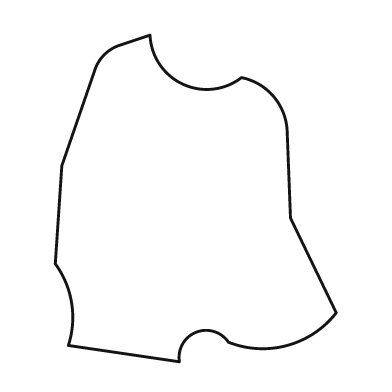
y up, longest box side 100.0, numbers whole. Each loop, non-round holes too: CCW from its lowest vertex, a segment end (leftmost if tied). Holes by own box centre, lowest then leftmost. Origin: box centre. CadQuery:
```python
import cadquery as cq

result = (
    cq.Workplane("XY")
    .moveTo(-5.0, -50.0)
    .threePointArc((0.0, -41.0), (10.0, -44.0))
    .threePointArc((28.0, -45.0), (43.0, -35.0))
    .lineTo(29.0, -6.0)
    .lineTo(28.0, 20.0)
    .threePointArc((24.0, 31.0), (14.0, 37.0))
    .threePointArc((-4.0, 35.0), (-14.0, 50.0))
    .lineTo(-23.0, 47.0)
    .threePointArc((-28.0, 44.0), (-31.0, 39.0))
    .lineTo(-41.0, 10.0)
    .lineTo(-43.0, -20.0)
    .threePointArc((-38.0, -32.0), (-39.0, -45.0))
    .close()
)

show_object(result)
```